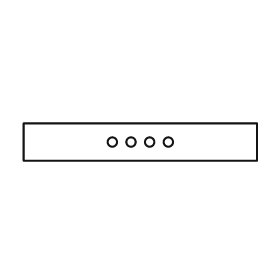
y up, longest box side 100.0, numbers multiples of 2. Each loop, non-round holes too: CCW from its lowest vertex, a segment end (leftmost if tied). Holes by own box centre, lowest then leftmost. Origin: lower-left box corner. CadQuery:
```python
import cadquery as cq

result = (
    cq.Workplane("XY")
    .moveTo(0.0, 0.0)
    .lineTo(100.0, 0.0)
    .lineTo(100.0, 16.0)
    .lineTo(0.0, 16.0)
    .close()
    .moveTo(38.0, 8.0)
    .circle(2.0)
    .moveTo(46.0, 8.0)
    .circle(2.0)
    .moveTo(54.0, 8.0)
    .circle(2.0)
    .moveTo(62.0, 8.0)
    .circle(2.0)
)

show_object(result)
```